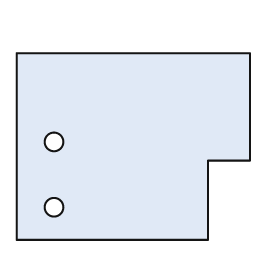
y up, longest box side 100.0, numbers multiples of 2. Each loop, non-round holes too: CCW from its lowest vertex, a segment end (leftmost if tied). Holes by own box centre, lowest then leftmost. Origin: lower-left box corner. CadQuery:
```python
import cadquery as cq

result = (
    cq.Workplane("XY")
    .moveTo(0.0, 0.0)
    .lineTo(82.0, 0.0)
    .lineTo(82.0, 34.0)
    .lineTo(100.0, 34.0)
    .lineTo(100.0, 80.0)
    .lineTo(0.0, 80.0)
    .close()
    .moveTo(16.0, 14.0)
    .circle(4.0)
    .moveTo(16.0, 42.0)
    .circle(4.0)
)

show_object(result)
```